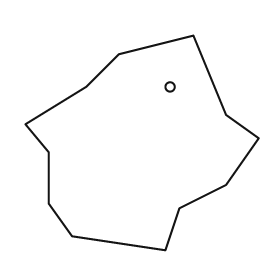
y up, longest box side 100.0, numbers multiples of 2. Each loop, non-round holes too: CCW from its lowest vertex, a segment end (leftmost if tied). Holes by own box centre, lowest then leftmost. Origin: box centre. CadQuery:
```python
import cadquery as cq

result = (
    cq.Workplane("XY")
    .moveTo(10.0, -46.0)
    .lineTo(16.0, -28.0)
    .lineTo(36.0, -18.0)
    .lineTo(50.0, 2.0)
    .lineTo(36.0, 12.0)
    .lineTo(22.0, 46.0)
    .lineTo(-10.0, 38.0)
    .lineTo(-24.0, 24.0)
    .lineTo(-50.0, 8.0)
    .lineTo(-40.0, -4.0)
    .lineTo(-40.0, -26.0)
    .lineTo(-30.0, -40.0)
    .close()
    .moveTo(12.0, 24.0)
    .circle(2.0)
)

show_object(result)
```